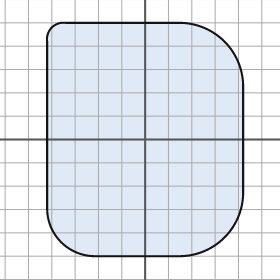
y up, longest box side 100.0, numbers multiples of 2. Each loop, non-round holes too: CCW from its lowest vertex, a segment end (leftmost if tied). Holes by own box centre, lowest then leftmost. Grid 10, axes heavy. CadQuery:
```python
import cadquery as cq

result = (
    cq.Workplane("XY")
    .moveTo(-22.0, -50.0)
    .lineTo(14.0, -50.0)
    .threePointArc((34.0, -42.0), (42.0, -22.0))
    .lineTo(42.0, 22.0)
    .threePointArc((34.0, 42.0), (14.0, 50.0))
    .lineTo(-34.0, 50.0)
    .threePointArc((-40.0, 48.0), (-42.0, 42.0))
    .lineTo(-42.0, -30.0)
    .threePointArc((-36.0, -44.0), (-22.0, -50.0))
    .close()
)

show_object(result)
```